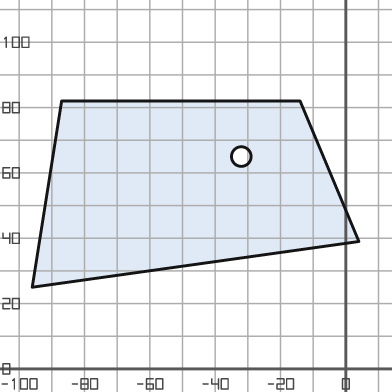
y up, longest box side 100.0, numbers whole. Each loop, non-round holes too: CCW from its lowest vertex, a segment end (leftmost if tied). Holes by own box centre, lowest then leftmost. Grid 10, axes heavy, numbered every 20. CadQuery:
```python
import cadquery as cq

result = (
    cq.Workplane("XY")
    .moveTo(-96.0, 25.0)
    .lineTo(4.0, 39.0)
    .lineTo(-14.0, 82.0)
    .lineTo(-87.0, 82.0)
    .close()
    .moveTo(-32.0, 65.0)
    .circle(3.0)
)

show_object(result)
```